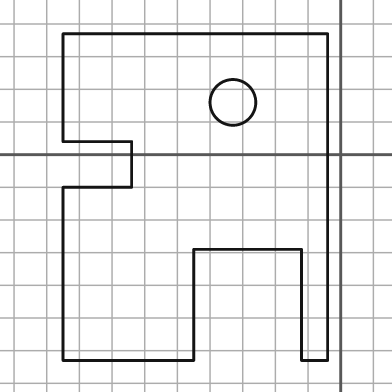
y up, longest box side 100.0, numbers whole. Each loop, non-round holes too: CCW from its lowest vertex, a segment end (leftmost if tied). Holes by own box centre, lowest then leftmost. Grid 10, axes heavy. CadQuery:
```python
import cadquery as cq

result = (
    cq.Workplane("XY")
    .moveTo(-85.0, -63.0)
    .lineTo(-45.0, -63.0)
    .lineTo(-45.0, -29.0)
    .lineTo(-12.0, -29.0)
    .lineTo(-12.0, -63.0)
    .lineTo(-4.0, -63.0)
    .lineTo(-4.0, 37.0)
    .lineTo(-85.0, 37.0)
    .lineTo(-85.0, 4.0)
    .lineTo(-64.0, 4.0)
    .lineTo(-64.0, -10.0)
    .lineTo(-85.0, -10.0)
    .close()
    .moveTo(-33.0, 16.0)
    .circle(7.0)
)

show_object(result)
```